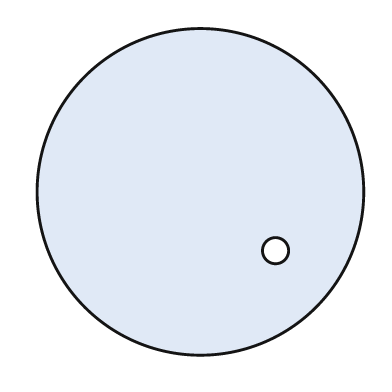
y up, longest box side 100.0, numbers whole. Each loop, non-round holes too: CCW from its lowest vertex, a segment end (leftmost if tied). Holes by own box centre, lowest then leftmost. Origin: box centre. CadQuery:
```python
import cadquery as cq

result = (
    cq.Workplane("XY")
    .moveTo(0.0, 0.0)
    .circle(50.0)
    .moveTo(23.0, -18.0)
    .circle(4.0)
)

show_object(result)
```